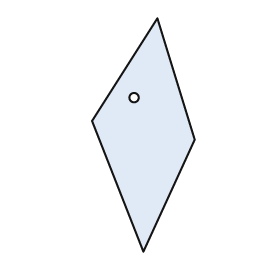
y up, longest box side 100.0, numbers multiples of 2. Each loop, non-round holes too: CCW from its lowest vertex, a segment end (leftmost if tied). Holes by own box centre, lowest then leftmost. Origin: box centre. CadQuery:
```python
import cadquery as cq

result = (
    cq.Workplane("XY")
    .moveTo(0.0, -50.0)
    .lineTo(22.0, -2.0)
    .lineTo(6.0, 50.0)
    .lineTo(-22.0, 6.0)
    .close()
    .moveTo(-4.0, 16.0)
    .circle(2.0)
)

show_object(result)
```